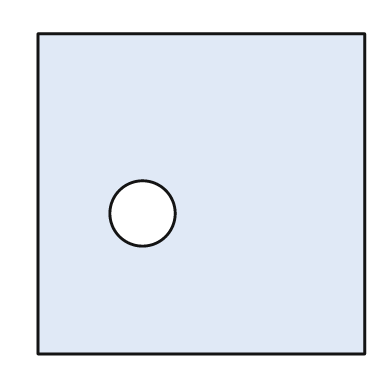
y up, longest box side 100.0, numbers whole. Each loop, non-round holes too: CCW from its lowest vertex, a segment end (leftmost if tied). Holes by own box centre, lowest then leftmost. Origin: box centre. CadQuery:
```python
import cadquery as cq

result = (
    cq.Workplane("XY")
    .moveTo(-50.0, -49.0)
    .lineTo(50.0, -49.0)
    .lineTo(50.0, 49.0)
    .lineTo(-50.0, 49.0)
    .close()
    .moveTo(-18.0, -6.0)
    .circle(10.0)
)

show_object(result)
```